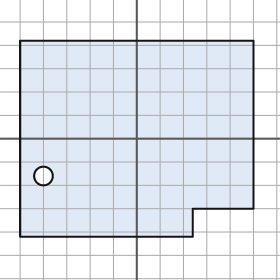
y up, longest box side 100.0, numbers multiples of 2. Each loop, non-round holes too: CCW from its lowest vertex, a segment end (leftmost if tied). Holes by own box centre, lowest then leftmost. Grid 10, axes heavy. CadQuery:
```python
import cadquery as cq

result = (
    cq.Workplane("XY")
    .moveTo(-50.0, -42.0)
    .lineTo(24.0, -42.0)
    .lineTo(24.0, -30.0)
    .lineTo(50.0, -30.0)
    .lineTo(50.0, 42.0)
    .lineTo(-50.0, 42.0)
    .close()
    .moveTo(-40.0, -16.0)
    .circle(4.0)
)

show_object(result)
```